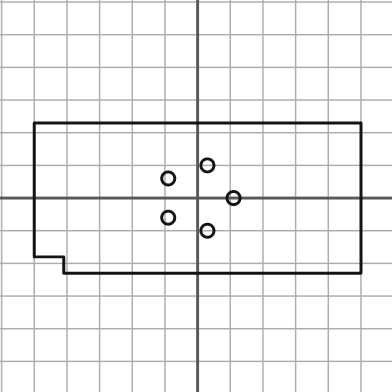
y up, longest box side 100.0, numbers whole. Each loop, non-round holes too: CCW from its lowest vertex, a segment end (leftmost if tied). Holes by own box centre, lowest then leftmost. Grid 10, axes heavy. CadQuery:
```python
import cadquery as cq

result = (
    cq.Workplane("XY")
    .moveTo(-41.0, -23.0)
    .lineTo(50.0, -23.0)
    .lineTo(50.0, 23.0)
    .lineTo(-50.0, 23.0)
    .lineTo(-50.0, -18.0)
    .lineTo(-41.0, -18.0)
    .close()
    .moveTo(3.0, -10.0)
    .circle(2.0)
    .moveTo(-9.0, -6.0)
    .circle(2.0)
    .moveTo(11.0, 0.0)
    .circle(2.0)
    .moveTo(-9.0, 6.0)
    .circle(2.0)
    .moveTo(3.0, 10.0)
    .circle(2.0)
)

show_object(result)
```